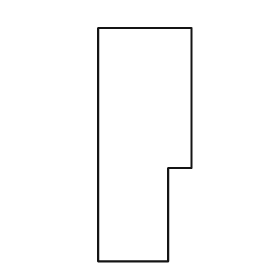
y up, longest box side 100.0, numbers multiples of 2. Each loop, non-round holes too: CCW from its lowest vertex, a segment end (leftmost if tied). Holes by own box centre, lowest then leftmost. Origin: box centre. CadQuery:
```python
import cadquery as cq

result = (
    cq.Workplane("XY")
    .moveTo(-20.0, -50.0)
    .lineTo(10.0, -50.0)
    .lineTo(10.0, -10.0)
    .lineTo(20.0, -10.0)
    .lineTo(20.0, 50.0)
    .lineTo(-20.0, 50.0)
    .close()
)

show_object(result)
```